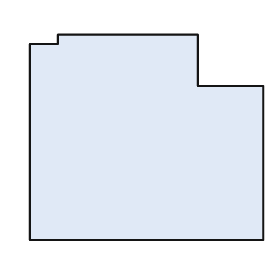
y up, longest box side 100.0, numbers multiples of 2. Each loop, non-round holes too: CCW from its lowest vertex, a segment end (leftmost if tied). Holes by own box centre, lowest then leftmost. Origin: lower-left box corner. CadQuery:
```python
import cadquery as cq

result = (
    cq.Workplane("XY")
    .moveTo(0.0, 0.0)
    .lineTo(100.0, 0.0)
    .lineTo(100.0, 66.0)
    .lineTo(72.0, 66.0)
    .lineTo(72.0, 88.0)
    .lineTo(12.0, 88.0)
    .lineTo(12.0, 84.0)
    .lineTo(0.0, 84.0)
    .close()
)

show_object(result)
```